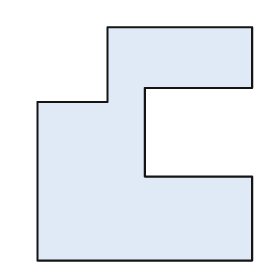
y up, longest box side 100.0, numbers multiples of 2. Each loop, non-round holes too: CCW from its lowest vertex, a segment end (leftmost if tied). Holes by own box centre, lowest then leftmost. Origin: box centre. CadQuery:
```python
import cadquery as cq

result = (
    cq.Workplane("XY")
    .moveTo(-46.0, -50.0)
    .lineTo(46.0, -50.0)
    .lineTo(46.0, -14.0)
    .lineTo(0.0, -14.0)
    .lineTo(0.0, 24.0)
    .lineTo(46.0, 24.0)
    .lineTo(46.0, 50.0)
    .lineTo(-16.0, 50.0)
    .lineTo(-16.0, 18.0)
    .lineTo(-46.0, 18.0)
    .close()
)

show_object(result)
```